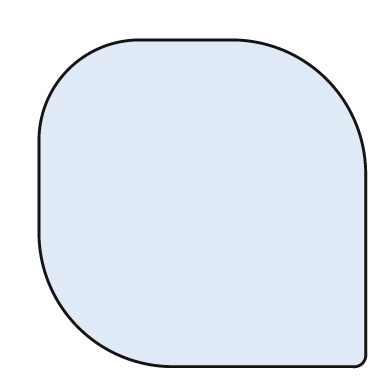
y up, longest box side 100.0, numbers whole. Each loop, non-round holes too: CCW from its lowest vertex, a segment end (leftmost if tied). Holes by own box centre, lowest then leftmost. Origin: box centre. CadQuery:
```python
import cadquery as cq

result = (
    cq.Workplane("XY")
    .moveTo(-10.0, -50.0)
    .lineTo(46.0, -50.0)
    .threePointArc((49.0, -49.0), (50.0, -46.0))
    .lineTo(50.0, 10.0)
    .threePointArc((38.0, 38.0), (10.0, 50.0))
    .lineTo(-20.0, 50.0)
    .threePointArc((-41.0, 41.0), (-50.0, 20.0))
    .lineTo(-50.0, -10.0)
    .threePointArc((-38.0, -38.0), (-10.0, -50.0))
    .close()
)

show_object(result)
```